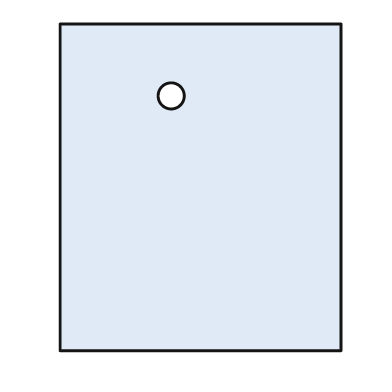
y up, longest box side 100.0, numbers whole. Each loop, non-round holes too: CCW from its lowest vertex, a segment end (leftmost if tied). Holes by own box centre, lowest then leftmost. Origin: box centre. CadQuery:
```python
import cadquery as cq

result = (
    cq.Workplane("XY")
    .moveTo(-43.0, -50.0)
    .lineTo(43.0, -50.0)
    .lineTo(43.0, 50.0)
    .lineTo(-43.0, 50.0)
    .close()
    .moveTo(-9.0, 28.0)
    .circle(4.0)
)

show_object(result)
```